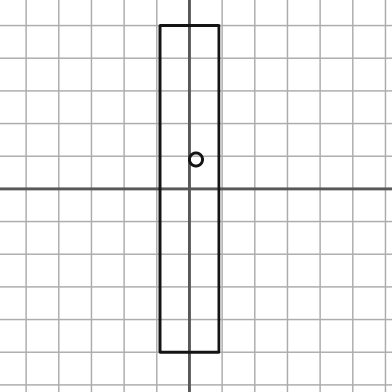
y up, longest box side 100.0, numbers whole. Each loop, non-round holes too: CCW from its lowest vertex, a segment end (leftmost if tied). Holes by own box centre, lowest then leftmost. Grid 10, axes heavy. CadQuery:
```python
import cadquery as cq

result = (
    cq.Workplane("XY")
    .moveTo(-9.0, -50.0)
    .lineTo(9.0, -50.0)
    .lineTo(9.0, 50.0)
    .lineTo(-9.0, 50.0)
    .close()
    .moveTo(2.0, 9.0)
    .circle(2.0)
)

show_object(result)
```